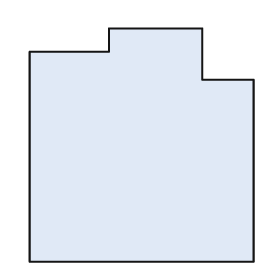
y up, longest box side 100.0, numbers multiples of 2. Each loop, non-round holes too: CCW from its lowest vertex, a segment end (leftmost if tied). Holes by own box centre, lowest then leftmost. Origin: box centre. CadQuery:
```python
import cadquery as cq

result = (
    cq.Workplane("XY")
    .moveTo(-48.0, -50.0)
    .lineTo(48.0, -50.0)
    .lineTo(48.0, 28.0)
    .lineTo(26.0, 28.0)
    .lineTo(26.0, 50.0)
    .lineTo(-14.0, 50.0)
    .lineTo(-14.0, 40.0)
    .lineTo(-48.0, 40.0)
    .close()
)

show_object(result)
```